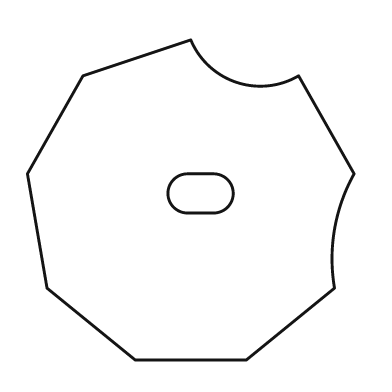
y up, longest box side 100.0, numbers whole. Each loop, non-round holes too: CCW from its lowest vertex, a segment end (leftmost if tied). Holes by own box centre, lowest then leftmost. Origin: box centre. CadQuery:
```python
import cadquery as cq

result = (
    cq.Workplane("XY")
    .moveTo(-17.0, -49.0)
    .lineTo(17.0, -49.0)
    .lineTo(44.0, -27.0)
    .threePointArc((44.0, -9.0), (50.0, 8.0))
    .lineTo(33.0, 38.0)
    .threePointArc((14.0, 36.0), (0.0, 49.0))
    .lineTo(-33.0, 38.0)
    .lineTo(-50.0, 8.0)
    .lineTo(-44.0, -27.0)
    .close()
    .moveTo(-1.0, -4.0)
    .lineTo(7.0, -4.0)
    .threePointArc((13.0, 2.0), (7.0, 8.0))
    .lineTo(-1.0, 8.0)
    .threePointArc((-7.0, 2.0), (-1.0, -4.0))
    .close()
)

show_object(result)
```